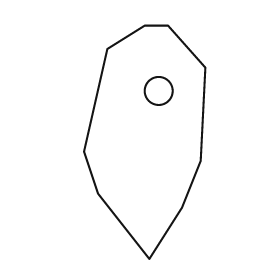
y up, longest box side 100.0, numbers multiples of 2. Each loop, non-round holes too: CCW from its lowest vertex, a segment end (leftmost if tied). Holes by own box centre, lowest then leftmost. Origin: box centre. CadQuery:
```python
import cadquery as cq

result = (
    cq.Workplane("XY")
    .moveTo(2.0, -50.0)
    .lineTo(16.0, -28.0)
    .lineTo(24.0, -8.0)
    .lineTo(26.0, 32.0)
    .lineTo(10.0, 50.0)
    .lineTo(0.0, 50.0)
    .lineTo(-16.0, 40.0)
    .lineTo(-26.0, -4.0)
    .lineTo(-20.0, -22.0)
    .close()
    .moveTo(6.0, 22.0)
    .circle(6.0)
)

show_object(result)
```